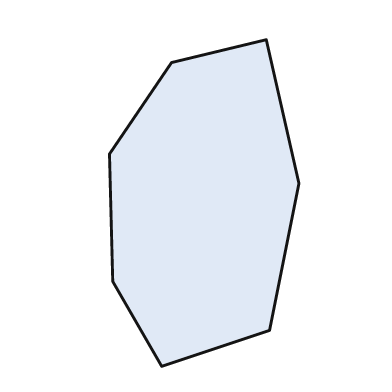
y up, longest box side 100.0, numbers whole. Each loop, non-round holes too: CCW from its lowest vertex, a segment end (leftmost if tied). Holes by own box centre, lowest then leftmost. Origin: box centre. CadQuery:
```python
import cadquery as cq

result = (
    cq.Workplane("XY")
    .moveTo(-13.0, -50.0)
    .lineTo(20.0, -39.0)
    .lineTo(29.0, 6.0)
    .lineTo(19.0, 50.0)
    .lineTo(-10.0, 43.0)
    .lineTo(-29.0, 15.0)
    .lineTo(-28.0, -24.0)
    .close()
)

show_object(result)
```